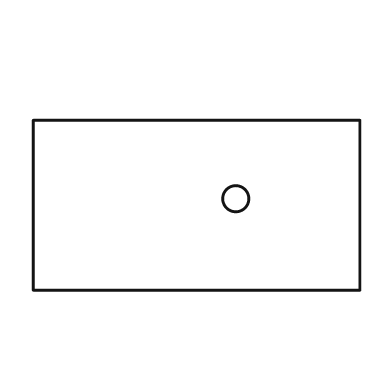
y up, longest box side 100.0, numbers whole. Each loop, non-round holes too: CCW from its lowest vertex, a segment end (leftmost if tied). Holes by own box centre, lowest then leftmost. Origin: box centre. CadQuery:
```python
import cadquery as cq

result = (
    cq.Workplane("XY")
    .moveTo(-50.0, -26.0)
    .lineTo(50.0, -26.0)
    .lineTo(50.0, 26.0)
    .lineTo(-50.0, 26.0)
    .close()
    .moveTo(12.0, 2.0)
    .circle(4.0)
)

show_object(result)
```